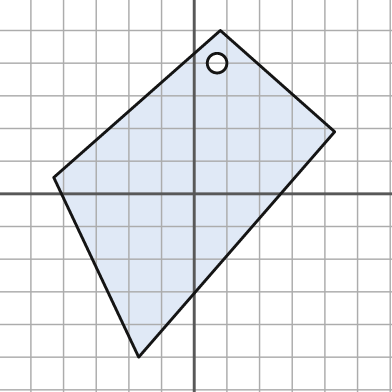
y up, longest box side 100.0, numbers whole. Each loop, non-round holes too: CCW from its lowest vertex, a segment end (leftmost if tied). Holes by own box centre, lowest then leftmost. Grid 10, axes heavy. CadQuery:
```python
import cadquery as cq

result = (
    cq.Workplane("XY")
    .moveTo(-17.0, -50.0)
    .lineTo(43.0, 19.0)
    .lineTo(8.0, 50.0)
    .lineTo(-43.0, 5.0)
    .close()
    .moveTo(7.0, 40.0)
    .circle(3.0)
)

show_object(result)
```